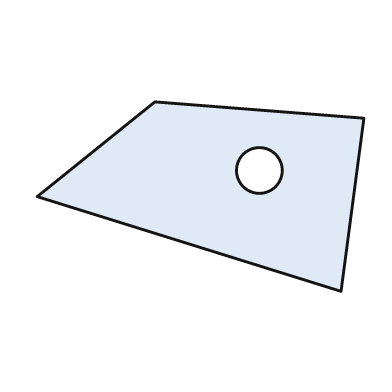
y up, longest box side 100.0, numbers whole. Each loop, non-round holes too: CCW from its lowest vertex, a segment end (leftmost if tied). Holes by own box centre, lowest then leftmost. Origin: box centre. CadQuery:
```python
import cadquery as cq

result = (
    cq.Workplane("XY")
    .moveTo(43.0, -29.0)
    .lineTo(50.0, 24.0)
    .lineTo(-14.0, 29.0)
    .lineTo(-50.0, 0.0)
    .close()
    .moveTo(18.0, 8.0)
    .circle(7.0)
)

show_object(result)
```